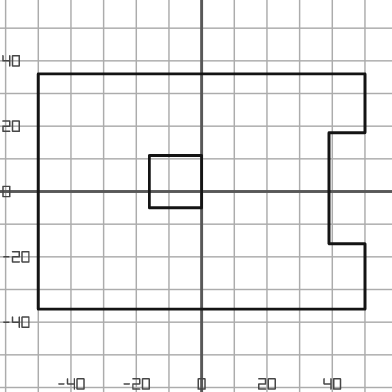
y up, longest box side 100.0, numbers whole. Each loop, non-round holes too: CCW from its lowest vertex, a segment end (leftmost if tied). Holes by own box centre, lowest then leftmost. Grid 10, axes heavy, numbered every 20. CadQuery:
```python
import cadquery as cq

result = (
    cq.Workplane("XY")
    .moveTo(-50.0, -36.0)
    .lineTo(50.0, -36.0)
    .lineTo(50.0, -16.0)
    .lineTo(39.0, -16.0)
    .lineTo(39.0, 18.0)
    .lineTo(50.0, 18.0)
    .lineTo(50.0, 36.0)
    .lineTo(-50.0, 36.0)
    .close()
    .moveTo(-16.0, -5.0)
    .lineTo(0.0, -5.0)
    .lineTo(0.0, 11.0)
    .lineTo(-16.0, 11.0)
    .close()
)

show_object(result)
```